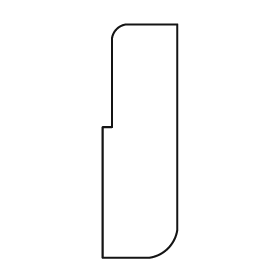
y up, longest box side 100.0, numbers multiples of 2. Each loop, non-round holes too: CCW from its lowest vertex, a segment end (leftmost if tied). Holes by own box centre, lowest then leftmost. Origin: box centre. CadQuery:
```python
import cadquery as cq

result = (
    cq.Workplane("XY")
    .moveTo(-16.0, -50.0)
    .lineTo(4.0, -50.0)
    .threePointArc((12.0, -46.0), (16.0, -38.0))
    .lineTo(16.0, 50.0)
    .lineTo(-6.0, 50.0)
    .threePointArc((-10.0, 48.0), (-12.0, 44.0))
    .lineTo(-12.0, 6.0)
    .lineTo(-16.0, 6.0)
    .close()
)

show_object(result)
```